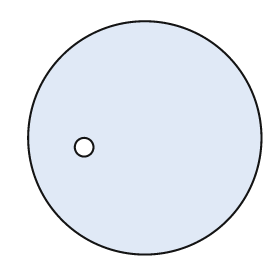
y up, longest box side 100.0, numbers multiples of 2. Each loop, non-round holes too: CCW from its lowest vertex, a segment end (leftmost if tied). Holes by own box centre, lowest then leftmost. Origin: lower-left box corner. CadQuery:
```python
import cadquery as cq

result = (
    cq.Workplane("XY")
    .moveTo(50.0, 50.0)
    .circle(50.0)
    .moveTo(24.0, 46.0)
    .circle(4.0)
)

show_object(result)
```